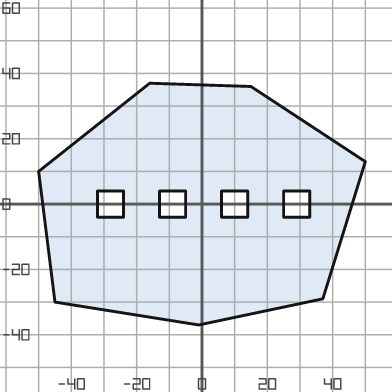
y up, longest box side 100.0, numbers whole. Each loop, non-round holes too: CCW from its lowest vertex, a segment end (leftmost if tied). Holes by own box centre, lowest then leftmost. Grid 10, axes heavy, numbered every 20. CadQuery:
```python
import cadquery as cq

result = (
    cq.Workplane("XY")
    .moveTo(-1.0, -37.0)
    .lineTo(37.0, -29.0)
    .lineTo(50.0, 13.0)
    .lineTo(15.0, 36.0)
    .lineTo(-16.0, 37.0)
    .lineTo(-50.0, 10.0)
    .lineTo(-45.0, -30.0)
    .close()
    .moveTo(-32.0, -4.0)
    .lineTo(-24.0, -4.0)
    .lineTo(-24.0, 4.0)
    .lineTo(-32.0, 4.0)
    .close()
    .moveTo(-13.0, -4.0)
    .lineTo(-5.0, -4.0)
    .lineTo(-5.0, 4.0)
    .lineTo(-13.0, 4.0)
    .close()
    .moveTo(6.0, -4.0)
    .lineTo(14.0, -4.0)
    .lineTo(14.0, 4.0)
    .lineTo(6.0, 4.0)
    .close()
    .moveTo(25.0, -4.0)
    .lineTo(33.0, -4.0)
    .lineTo(33.0, 4.0)
    .lineTo(25.0, 4.0)
    .close()
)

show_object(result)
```